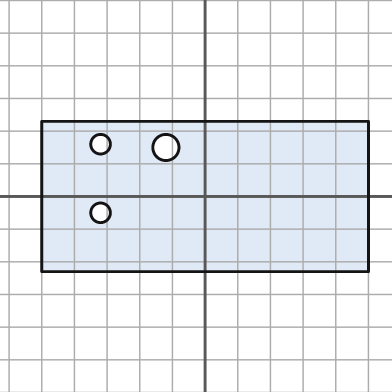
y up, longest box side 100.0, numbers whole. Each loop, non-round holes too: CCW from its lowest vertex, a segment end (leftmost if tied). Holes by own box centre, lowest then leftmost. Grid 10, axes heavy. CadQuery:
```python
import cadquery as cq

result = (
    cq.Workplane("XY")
    .moveTo(-50.0, -23.0)
    .lineTo(50.0, -23.0)
    .lineTo(50.0, 23.0)
    .lineTo(-50.0, 23.0)
    .close()
    .moveTo(-32.0, -5.0)
    .circle(3.0)
    .moveTo(-12.0, 15.0)
    .circle(4.0)
    .moveTo(-32.0, 16.0)
    .circle(3.0)
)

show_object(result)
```